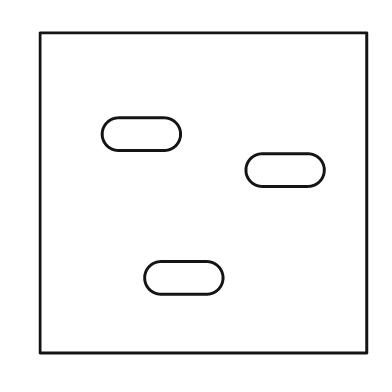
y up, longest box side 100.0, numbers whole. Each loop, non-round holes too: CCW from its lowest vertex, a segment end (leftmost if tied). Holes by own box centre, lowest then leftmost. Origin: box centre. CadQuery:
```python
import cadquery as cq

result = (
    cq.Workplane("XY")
    .moveTo(-50.0, -49.0)
    .lineTo(50.0, -49.0)
    .lineTo(50.0, 49.0)
    .lineTo(-50.0, 49.0)
    .close()
    .moveTo(-13.0, -31.0)
    .lineTo(1.0, -31.0)
    .threePointArc((6.0, -26.0), (1.0, -21.0))
    .lineTo(-13.0, -21.0)
    .threePointArc((-18.0, -26.0), (-13.0, -31.0))
    .close()
    .moveTo(18.0, 2.0)
    .lineTo(32.0, 2.0)
    .threePointArc((37.0, 7.0), (32.0, 12.0))
    .lineTo(18.0, 12.0)
    .threePointArc((13.0, 7.0), (18.0, 2.0))
    .close()
    .moveTo(-26.0, 13.0)
    .lineTo(-12.0, 13.0)
    .threePointArc((-7.0, 18.0), (-12.0, 23.0))
    .lineTo(-26.0, 23.0)
    .threePointArc((-31.0, 18.0), (-26.0, 13.0))
    .close()
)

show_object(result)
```